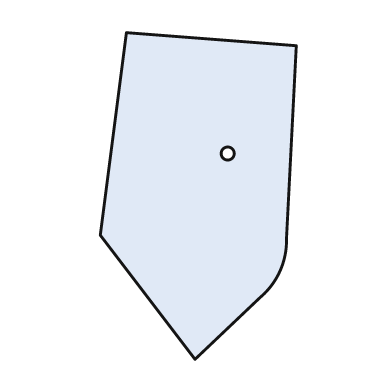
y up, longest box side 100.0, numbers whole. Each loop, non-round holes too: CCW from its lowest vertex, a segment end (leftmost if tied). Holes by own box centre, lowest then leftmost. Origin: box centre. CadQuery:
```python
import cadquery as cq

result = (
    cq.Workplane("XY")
    .moveTo(-1.0, -50.0)
    .lineTo(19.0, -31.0)
    .threePointArc((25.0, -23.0), (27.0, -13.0))
    .lineTo(30.0, 46.0)
    .lineTo(-22.0, 50.0)
    .lineTo(-30.0, -12.0)
    .close()
    .moveTo(9.0, 13.0)
    .circle(2.0)
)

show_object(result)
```